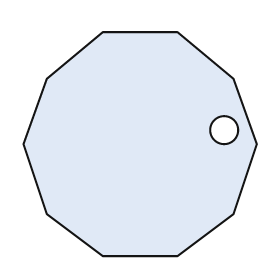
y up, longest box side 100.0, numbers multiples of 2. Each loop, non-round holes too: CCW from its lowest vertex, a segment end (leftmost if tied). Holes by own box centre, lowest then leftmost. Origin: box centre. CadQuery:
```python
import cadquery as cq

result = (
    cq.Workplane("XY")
    .moveTo(-16.0, -48.0)
    .lineTo(16.0, -48.0)
    .lineTo(40.0, -30.0)
    .lineTo(50.0, 0.0)
    .lineTo(40.0, 28.0)
    .lineTo(16.0, 48.0)
    .lineTo(-16.0, 48.0)
    .lineTo(-40.0, 28.0)
    .lineTo(-50.0, 0.0)
    .lineTo(-40.0, -30.0)
    .close()
    .moveTo(36.0, 6.0)
    .circle(6.0)
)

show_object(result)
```